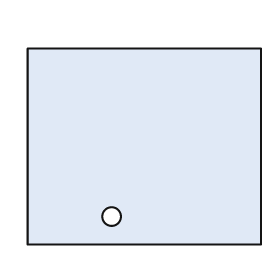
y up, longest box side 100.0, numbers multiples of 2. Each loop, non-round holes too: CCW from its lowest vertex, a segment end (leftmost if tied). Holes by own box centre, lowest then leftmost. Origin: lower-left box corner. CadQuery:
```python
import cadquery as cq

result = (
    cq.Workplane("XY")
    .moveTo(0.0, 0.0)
    .lineTo(100.0, 0.0)
    .lineTo(100.0, 84.0)
    .lineTo(0.0, 84.0)
    .close()
    .moveTo(36.0, 12.0)
    .circle(4.0)
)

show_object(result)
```